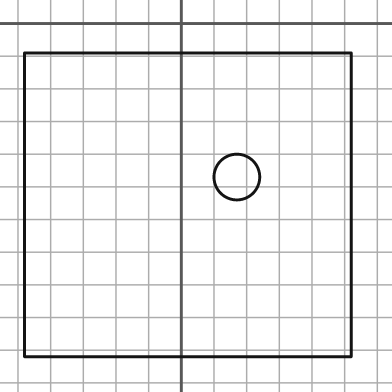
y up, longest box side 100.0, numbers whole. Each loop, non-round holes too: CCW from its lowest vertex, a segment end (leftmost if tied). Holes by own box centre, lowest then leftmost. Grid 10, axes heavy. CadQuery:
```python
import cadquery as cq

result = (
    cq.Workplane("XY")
    .moveTo(-48.0, -102.0)
    .lineTo(52.0, -102.0)
    .lineTo(52.0, -9.0)
    .lineTo(-48.0, -9.0)
    .close()
    .moveTo(17.0, -47.0)
    .circle(7.0)
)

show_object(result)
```